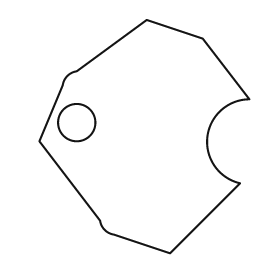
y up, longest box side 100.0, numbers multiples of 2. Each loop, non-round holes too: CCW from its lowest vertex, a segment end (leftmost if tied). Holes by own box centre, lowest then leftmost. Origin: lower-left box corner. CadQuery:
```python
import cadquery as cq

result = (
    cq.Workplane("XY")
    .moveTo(56.0, 0.0)
    .lineTo(86.0, 30.0)
    .threePointArc((72.0, 50.0), (90.0, 66.0))
    .lineTo(70.0, 92.0)
    .lineTo(46.0, 100.0)
    .lineTo(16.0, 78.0)
    .threePointArc((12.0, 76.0), (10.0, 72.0))
    .lineTo(0.0, 48.0)
    .lineTo(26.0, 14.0)
    .threePointArc((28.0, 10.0), (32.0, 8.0))
    .close()
    .moveTo(16.0, 56.0)
    .circle(8.0)
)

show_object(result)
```